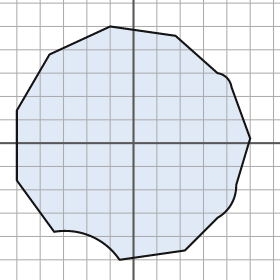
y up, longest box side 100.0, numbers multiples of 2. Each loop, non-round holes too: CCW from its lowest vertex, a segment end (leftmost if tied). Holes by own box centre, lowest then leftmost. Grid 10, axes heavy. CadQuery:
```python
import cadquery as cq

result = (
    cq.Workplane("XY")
    .moveTo(-6.0, -50.0)
    .lineTo(22.0, -46.0)
    .lineTo(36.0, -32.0)
    .threePointArc((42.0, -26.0), (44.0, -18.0))
    .lineTo(50.0, 2.0)
    .lineTo(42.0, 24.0)
    .threePointArc((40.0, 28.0), (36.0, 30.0))
    .lineTo(18.0, 46.0)
    .lineTo(-10.0, 50.0)
    .lineTo(-36.0, 38.0)
    .lineTo(-50.0, 14.0)
    .lineTo(-50.0, -16.0)
    .lineTo(-34.0, -38.0)
    .threePointArc((-18.0, -40.0), (-6.0, -50.0))
    .close()
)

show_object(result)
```